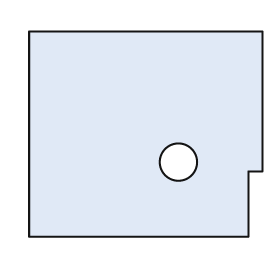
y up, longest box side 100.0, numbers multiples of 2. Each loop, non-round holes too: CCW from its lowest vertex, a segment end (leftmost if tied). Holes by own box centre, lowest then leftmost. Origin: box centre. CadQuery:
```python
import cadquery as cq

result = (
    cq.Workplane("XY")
    .moveTo(-50.0, -44.0)
    .lineTo(44.0, -44.0)
    .lineTo(44.0, -16.0)
    .lineTo(50.0, -16.0)
    .lineTo(50.0, 44.0)
    .lineTo(-50.0, 44.0)
    .close()
    .moveTo(14.0, -12.0)
    .circle(8.0)
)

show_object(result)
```